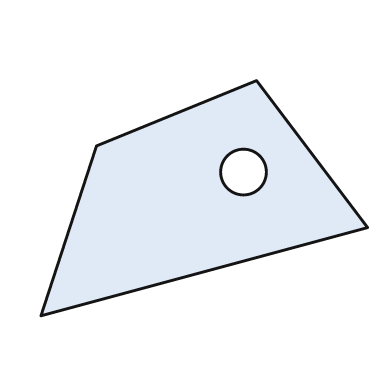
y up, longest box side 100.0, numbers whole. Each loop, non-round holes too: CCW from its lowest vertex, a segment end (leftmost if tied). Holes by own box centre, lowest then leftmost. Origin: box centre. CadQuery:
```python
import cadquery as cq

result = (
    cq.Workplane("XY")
    .moveTo(-50.0, -36.0)
    .lineTo(50.0, -9.0)
    .lineTo(16.0, 36.0)
    .lineTo(-33.0, 16.0)
    .close()
    .moveTo(12.0, 8.0)
    .circle(7.0)
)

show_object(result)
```